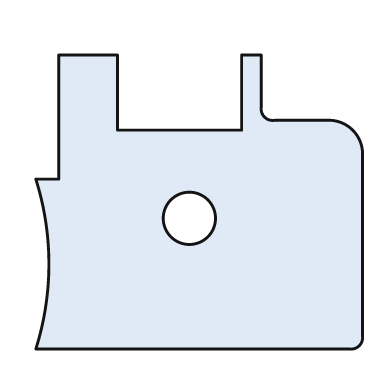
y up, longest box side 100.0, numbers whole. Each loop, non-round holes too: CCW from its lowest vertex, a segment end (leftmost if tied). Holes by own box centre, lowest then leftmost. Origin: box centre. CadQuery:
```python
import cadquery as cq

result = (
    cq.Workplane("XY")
    .moveTo(-50.0, -45.0)
    .lineTo(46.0, -45.0)
    .threePointArc((49.0, -44.0), (50.0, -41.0))
    .lineTo(50.0, 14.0)
    .threePointArc((47.0, 22.0), (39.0, 25.0))
    .lineTo(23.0, 25.0)
    .threePointArc((20.0, 26.0), (19.0, 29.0))
    .lineTo(19.0, 45.0)
    .lineTo(13.0, 45.0)
    .lineTo(13.0, 22.0)
    .lineTo(-25.0, 22.0)
    .lineTo(-25.0, 45.0)
    .lineTo(-43.0, 45.0)
    .lineTo(-43.0, 7.0)
    .lineTo(-50.0, 7.0)
    .threePointArc((-46.0, -19.0), (-50.0, -45.0))
    .close()
    .moveTo(-3.0, -5.0)
    .circle(8.0)
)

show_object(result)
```